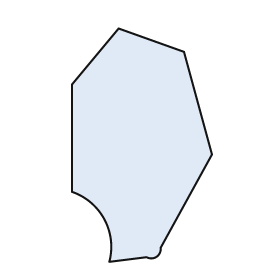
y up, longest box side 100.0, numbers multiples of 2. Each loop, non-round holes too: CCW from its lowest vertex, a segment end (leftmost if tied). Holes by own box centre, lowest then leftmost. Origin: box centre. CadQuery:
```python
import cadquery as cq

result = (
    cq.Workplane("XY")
    .moveTo(-14.0, -50.0)
    .lineTo(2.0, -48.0)
    .threePointArc((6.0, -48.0), (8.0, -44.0))
    .lineTo(30.0, -4.0)
    .lineTo(18.0, 40.0)
    .lineTo(-10.0, 50.0)
    .lineTo(-30.0, 26.0)
    .lineTo(-30.0, -20.0)
    .threePointArc((-16.0, -32.0), (-14.0, -50.0))
    .close()
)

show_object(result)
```